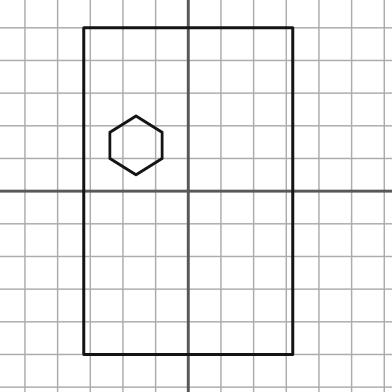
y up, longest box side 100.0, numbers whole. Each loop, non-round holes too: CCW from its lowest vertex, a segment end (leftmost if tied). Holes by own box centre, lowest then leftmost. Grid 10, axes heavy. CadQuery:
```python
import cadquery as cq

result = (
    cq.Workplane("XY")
    .moveTo(-32.0, -50.0)
    .lineTo(32.0, -50.0)
    .lineTo(32.0, 50.0)
    .lineTo(-32.0, 50.0)
    .close()
    .moveTo(-16.0, 5.0)
    .lineTo(-8.0, 10.0)
    .lineTo(-8.0, 18.0)
    .lineTo(-16.0, 23.0)
    .lineTo(-24.0, 18.0)
    .lineTo(-24.0, 10.0)
    .close()
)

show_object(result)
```